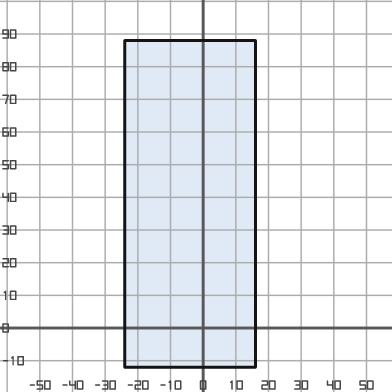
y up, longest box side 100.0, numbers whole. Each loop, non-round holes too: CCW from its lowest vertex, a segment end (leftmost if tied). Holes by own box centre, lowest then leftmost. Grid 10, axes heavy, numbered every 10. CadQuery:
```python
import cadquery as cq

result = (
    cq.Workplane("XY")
    .moveTo(-24.0, -12.0)
    .lineTo(16.0, -12.0)
    .lineTo(16.0, 88.0)
    .lineTo(-24.0, 88.0)
    .close()
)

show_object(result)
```